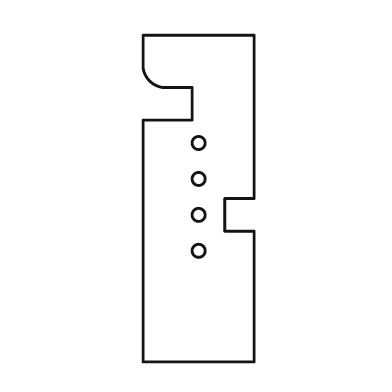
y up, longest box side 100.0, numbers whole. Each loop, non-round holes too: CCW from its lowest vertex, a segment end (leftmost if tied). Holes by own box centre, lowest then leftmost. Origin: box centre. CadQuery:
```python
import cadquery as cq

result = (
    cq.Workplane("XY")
    .moveTo(-17.0, -50.0)
    .lineTo(17.0, -50.0)
    .lineTo(17.0, -10.0)
    .lineTo(8.0, -10.0)
    .lineTo(8.0, 0.0)
    .lineTo(17.0, 0.0)
    .lineTo(17.0, 50.0)
    .lineTo(-17.0, 50.0)
    .lineTo(-17.0, 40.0)
    .threePointArc((-15.0, 36.0), (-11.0, 34.0))
    .lineTo(-2.0, 34.0)
    .lineTo(-2.0, 24.0)
    .lineTo(-17.0, 24.0)
    .close()
    .moveTo(0.0, -16.0)
    .circle(2.0)
    .moveTo(0.0, -5.0)
    .circle(2.0)
    .moveTo(0.0, 6.0)
    .circle(2.0)
    .moveTo(0.0, 17.0)
    .circle(2.0)
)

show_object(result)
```